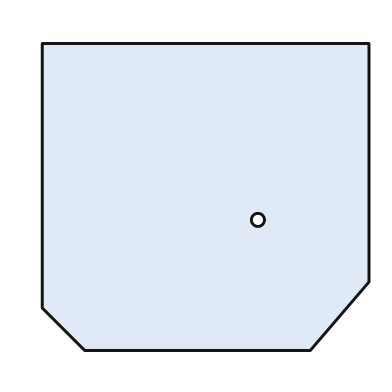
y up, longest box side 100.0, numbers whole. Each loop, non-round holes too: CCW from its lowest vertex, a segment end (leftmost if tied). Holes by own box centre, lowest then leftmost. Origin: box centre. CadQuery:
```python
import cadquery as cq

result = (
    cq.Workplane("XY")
    .moveTo(-37.0, -47.0)
    .lineTo(32.0, -47.0)
    .lineTo(50.0, -26.0)
    .lineTo(50.0, 47.0)
    .lineTo(-50.0, 47.0)
    .lineTo(-50.0, -34.0)
    .close()
    .moveTo(16.0, -7.0)
    .circle(2.0)
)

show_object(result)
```